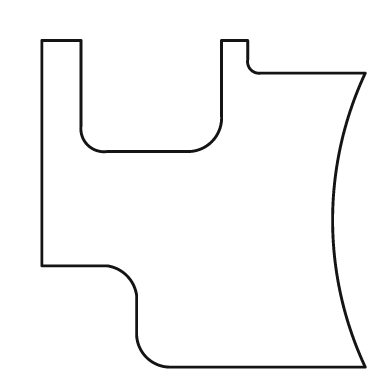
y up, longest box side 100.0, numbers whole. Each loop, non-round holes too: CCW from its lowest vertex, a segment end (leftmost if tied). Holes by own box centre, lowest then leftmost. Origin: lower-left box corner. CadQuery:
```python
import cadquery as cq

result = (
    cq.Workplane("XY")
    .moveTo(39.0, 0.0)
    .lineTo(99.0, 0.0)
    .threePointArc((89.0, 45.0), (99.0, 90.0))
    .lineTo(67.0, 90.0)
    .threePointArc((64.0, 91.0), (63.0, 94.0))
    .lineTo(63.0, 100.0)
    .lineTo(55.0, 100.0)
    .lineTo(55.0, 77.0)
    .threePointArc((52.0, 69.0), (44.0, 66.0))
    .lineTo(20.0, 66.0)
    .threePointArc((14.0, 68.0), (12.0, 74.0))
    .lineTo(12.0, 100.0)
    .lineTo(0.0, 100.0)
    .lineTo(0.0, 31.0)
    .lineTo(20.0, 31.0)
    .threePointArc((26.0, 28.0), (29.0, 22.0))
    .lineTo(29.0, 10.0)
    .threePointArc((32.0, 3.0), (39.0, 0.0))
    .close()
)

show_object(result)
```